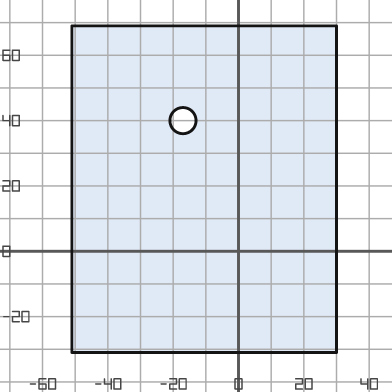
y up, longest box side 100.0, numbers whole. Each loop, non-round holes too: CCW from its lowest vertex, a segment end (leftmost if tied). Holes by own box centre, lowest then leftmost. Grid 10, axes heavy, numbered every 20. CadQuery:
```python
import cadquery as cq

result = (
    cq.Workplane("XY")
    .moveTo(-51.0, -31.0)
    .lineTo(30.0, -31.0)
    .lineTo(30.0, 69.0)
    .lineTo(-51.0, 69.0)
    .close()
    .moveTo(-17.0, 40.0)
    .circle(4.0)
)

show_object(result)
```